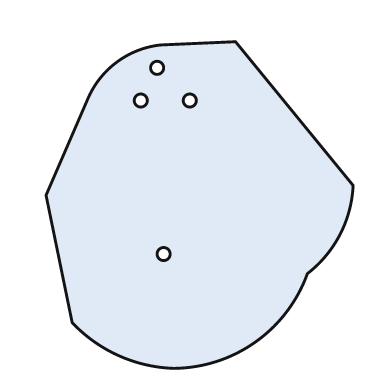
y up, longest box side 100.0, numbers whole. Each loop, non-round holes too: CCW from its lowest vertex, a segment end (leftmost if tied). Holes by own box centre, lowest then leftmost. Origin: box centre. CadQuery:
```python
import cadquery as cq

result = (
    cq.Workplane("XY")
    .moveTo(-8.0, -50.0)
    .threePointArc((17.0, -42.0), (33.0, -21.0))
    .threePointArc((43.0, -9.0), (47.0, 6.0))
    .lineTo(11.0, 50.0)
    .lineTo(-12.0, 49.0)
    .threePointArc((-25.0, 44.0), (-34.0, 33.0))
    .lineTo(-47.0, 3.0)
    .lineTo(-39.0, -36.0)
    .threePointArc((-25.0, -46.0), (-8.0, -50.0))
    .close()
    .moveTo(-11.0, -15.0)
    .circle(2.0)
    .moveTo(-18.0, 32.0)
    .circle(2.0)
    .moveTo(-3.0, 32.0)
    .circle(2.0)
    .moveTo(-13.0, 42.0)
    .circle(2.0)
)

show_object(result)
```